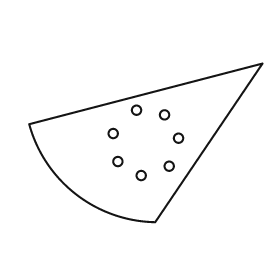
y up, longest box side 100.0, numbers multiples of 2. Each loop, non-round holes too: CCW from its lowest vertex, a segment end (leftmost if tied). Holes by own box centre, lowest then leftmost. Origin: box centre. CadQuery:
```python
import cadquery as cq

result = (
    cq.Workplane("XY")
    .moveTo(4.0, -34.0)
    .lineTo(50.0, 34.0)
    .lineTo(-50.0, 8.0)
    .threePointArc((-30.0, -22.0), (4.0, -34.0))
    .close()
    .moveTo(-2.0, -14.0)
    .circle(2.0)
    .moveTo(10.0, -10.0)
    .circle(2.0)
    .moveTo(-12.0, -8.0)
    .circle(2.0)
    .moveTo(14.0, 2.0)
    .circle(2.0)
    .moveTo(-14.0, 4.0)
    .circle(2.0)
    .moveTo(8.0, 12.0)
    .circle(2.0)
    .moveTo(-4.0, 14.0)
    .circle(2.0)
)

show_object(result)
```